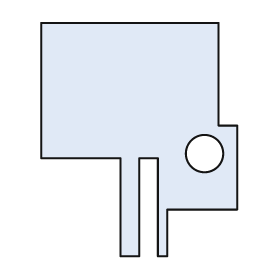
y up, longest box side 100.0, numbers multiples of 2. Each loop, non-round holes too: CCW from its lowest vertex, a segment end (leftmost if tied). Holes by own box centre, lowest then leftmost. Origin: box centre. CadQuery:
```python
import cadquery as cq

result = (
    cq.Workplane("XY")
    .moveTo(-8.0, -50.0)
    .lineTo(0.0, -50.0)
    .lineTo(0.0, -8.0)
    .lineTo(8.0, -8.0)
    .lineTo(8.0, -50.0)
    .lineTo(12.0, -50.0)
    .lineTo(12.0, -30.0)
    .lineTo(42.0, -30.0)
    .lineTo(42.0, 6.0)
    .lineTo(34.0, 6.0)
    .lineTo(34.0, 50.0)
    .lineTo(-42.0, 50.0)
    .lineTo(-42.0, -8.0)
    .lineTo(-8.0, -8.0)
    .close()
    .moveTo(28.0, -6.0)
    .circle(8.0)
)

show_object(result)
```